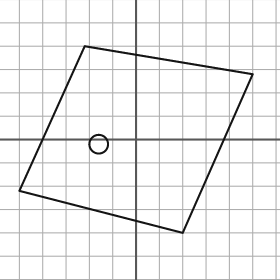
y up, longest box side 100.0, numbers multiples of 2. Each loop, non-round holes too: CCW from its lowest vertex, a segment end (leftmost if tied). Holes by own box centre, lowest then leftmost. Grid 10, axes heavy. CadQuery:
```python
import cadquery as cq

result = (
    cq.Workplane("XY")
    .moveTo(20.0, -40.0)
    .lineTo(50.0, 28.0)
    .lineTo(-22.0, 40.0)
    .lineTo(-50.0, -22.0)
    .close()
    .moveTo(-16.0, -2.0)
    .circle(4.0)
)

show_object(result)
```